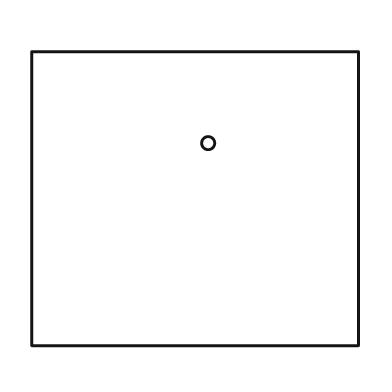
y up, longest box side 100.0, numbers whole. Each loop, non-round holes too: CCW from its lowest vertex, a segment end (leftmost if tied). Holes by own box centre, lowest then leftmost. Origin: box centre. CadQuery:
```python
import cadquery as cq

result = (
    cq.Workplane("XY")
    .moveTo(-50.0, -45.0)
    .lineTo(50.0, -45.0)
    .lineTo(50.0, 45.0)
    .lineTo(-50.0, 45.0)
    .close()
    .moveTo(4.0, 17.0)
    .circle(2.0)
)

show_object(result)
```